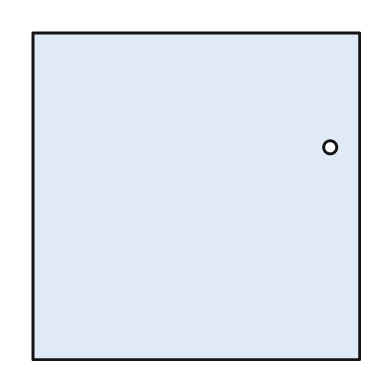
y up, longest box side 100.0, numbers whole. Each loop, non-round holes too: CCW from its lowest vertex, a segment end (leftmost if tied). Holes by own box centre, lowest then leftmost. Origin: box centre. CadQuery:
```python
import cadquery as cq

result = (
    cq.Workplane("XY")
    .moveTo(-50.0, -50.0)
    .lineTo(50.0, -50.0)
    .lineTo(50.0, 50.0)
    .lineTo(-50.0, 50.0)
    .close()
    .moveTo(41.0, 15.0)
    .circle(2.0)
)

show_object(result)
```